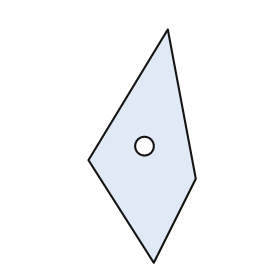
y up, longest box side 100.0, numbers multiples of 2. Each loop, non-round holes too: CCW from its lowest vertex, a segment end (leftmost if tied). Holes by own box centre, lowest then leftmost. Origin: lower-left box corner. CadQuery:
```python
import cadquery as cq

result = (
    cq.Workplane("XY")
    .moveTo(28.0, 0.0)
    .lineTo(46.0, 36.0)
    .lineTo(34.0, 100.0)
    .lineTo(0.0, 44.0)
    .close()
    .moveTo(24.0, 50.0)
    .circle(4.0)
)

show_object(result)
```